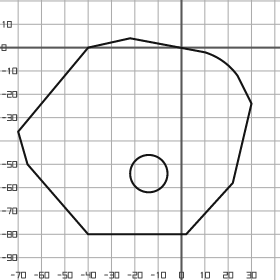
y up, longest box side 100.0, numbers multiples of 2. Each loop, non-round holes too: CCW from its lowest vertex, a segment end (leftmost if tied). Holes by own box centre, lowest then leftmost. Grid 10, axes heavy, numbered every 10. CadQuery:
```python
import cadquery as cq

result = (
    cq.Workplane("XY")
    .moveTo(-40.0, -80.0)
    .lineTo(2.0, -80.0)
    .lineTo(22.0, -58.0)
    .lineTo(30.0, -24.0)
    .lineTo(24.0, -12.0)
    .threePointArc((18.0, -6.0), (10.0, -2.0))
    .lineTo(-22.0, 4.0)
    .lineTo(-40.0, 0.0)
    .lineTo(-70.0, -36.0)
    .lineTo(-66.0, -50.0)
    .close()
    .moveTo(-14.0, -54.0)
    .circle(8.0)
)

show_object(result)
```